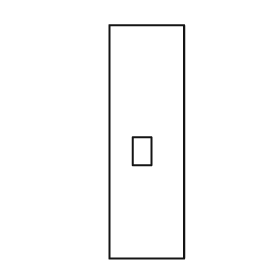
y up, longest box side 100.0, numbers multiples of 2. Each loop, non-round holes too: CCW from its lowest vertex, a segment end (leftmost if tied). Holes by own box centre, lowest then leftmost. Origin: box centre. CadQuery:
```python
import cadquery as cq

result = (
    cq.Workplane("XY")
    .moveTo(-16.0, -50.0)
    .lineTo(16.0, -50.0)
    .lineTo(16.0, 50.0)
    .lineTo(-16.0, 50.0)
    .close()
    .moveTo(-6.0, -10.0)
    .lineTo(2.0, -10.0)
    .lineTo(2.0, 2.0)
    .lineTo(-6.0, 2.0)
    .close()
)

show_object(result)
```